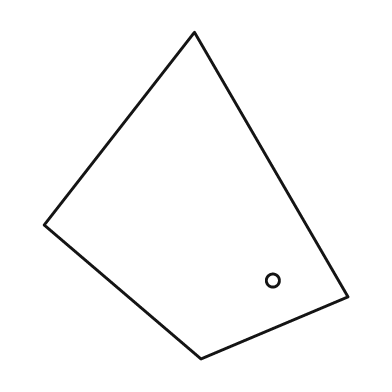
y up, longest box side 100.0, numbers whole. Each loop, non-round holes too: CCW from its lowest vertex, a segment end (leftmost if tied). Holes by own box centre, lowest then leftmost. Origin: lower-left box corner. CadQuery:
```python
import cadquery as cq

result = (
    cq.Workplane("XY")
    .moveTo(48.0, 0.0)
    .lineTo(93.0, 19.0)
    .lineTo(46.0, 100.0)
    .lineTo(0.0, 41.0)
    .close()
    .moveTo(70.0, 24.0)
    .circle(2.0)
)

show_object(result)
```